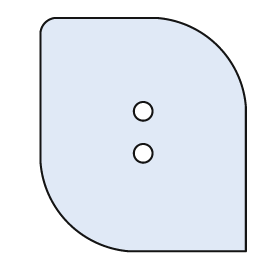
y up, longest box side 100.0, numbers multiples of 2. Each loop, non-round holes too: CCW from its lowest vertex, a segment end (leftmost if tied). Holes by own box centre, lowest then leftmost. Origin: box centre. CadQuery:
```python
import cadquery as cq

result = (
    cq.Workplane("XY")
    .moveTo(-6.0, -50.0)
    .lineTo(44.0, -50.0)
    .lineTo(44.0, 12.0)
    .threePointArc((32.0, 38.0), (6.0, 50.0))
    .lineTo(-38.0, 50.0)
    .threePointArc((-42.0, 48.0), (-44.0, 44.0))
    .lineTo(-44.0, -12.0)
    .threePointArc((-32.0, -38.0), (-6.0, -50.0))
    .close()
    .moveTo(0.0, -8.0)
    .circle(4.0)
    .moveTo(0.0, 10.0)
    .circle(4.0)
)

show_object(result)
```